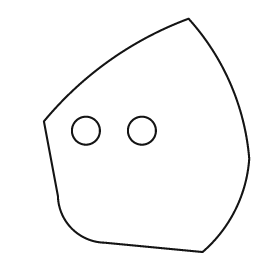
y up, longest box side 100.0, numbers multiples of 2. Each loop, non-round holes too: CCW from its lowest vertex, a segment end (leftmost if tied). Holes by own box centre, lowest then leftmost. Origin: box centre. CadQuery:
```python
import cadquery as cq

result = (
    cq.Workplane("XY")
    .moveTo(24.0, -50.0)
    .threePointArc((38.0, -32.0), (44.0, -10.0))
    .threePointArc((36.0, 22.0), (18.0, 50.0))
    .threePointArc((-16.0, 32.0), (-44.0, 6.0))
    .lineTo(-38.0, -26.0)
    .threePointArc((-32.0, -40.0), (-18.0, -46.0))
    .close()
    .moveTo(-26.0, 2.0)
    .circle(6.0)
    .moveTo(-2.0, 2.0)
    .circle(6.0)
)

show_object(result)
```